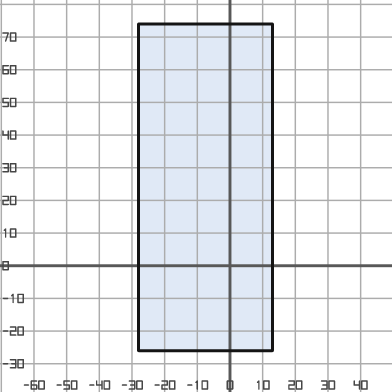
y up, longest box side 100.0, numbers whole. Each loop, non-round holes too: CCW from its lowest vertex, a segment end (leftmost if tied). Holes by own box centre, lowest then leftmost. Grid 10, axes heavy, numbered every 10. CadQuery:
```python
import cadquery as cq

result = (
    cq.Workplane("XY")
    .moveTo(-28.0, -26.0)
    .lineTo(13.0, -26.0)
    .lineTo(13.0, 74.0)
    .lineTo(-28.0, 74.0)
    .close()
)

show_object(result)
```